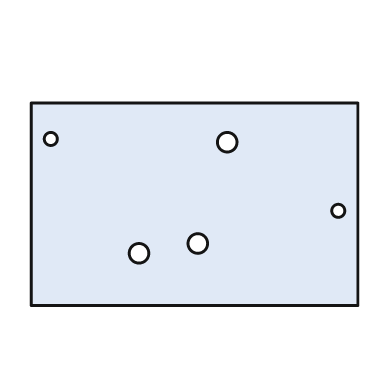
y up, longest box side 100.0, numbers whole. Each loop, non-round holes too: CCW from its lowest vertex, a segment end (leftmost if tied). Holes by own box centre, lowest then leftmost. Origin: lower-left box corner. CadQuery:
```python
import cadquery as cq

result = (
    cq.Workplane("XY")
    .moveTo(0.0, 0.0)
    .lineTo(100.0, 0.0)
    .lineTo(100.0, 62.0)
    .lineTo(0.0, 62.0)
    .close()
    .moveTo(33.0, 16.0)
    .circle(3.0)
    .moveTo(51.0, 19.0)
    .circle(3.0)
    .moveTo(94.0, 29.0)
    .circle(2.0)
    .moveTo(60.0, 50.0)
    .circle(3.0)
    .moveTo(6.0, 51.0)
    .circle(2.0)
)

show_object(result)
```